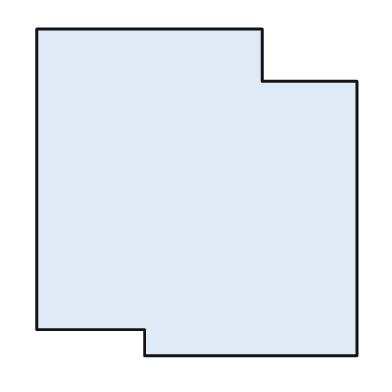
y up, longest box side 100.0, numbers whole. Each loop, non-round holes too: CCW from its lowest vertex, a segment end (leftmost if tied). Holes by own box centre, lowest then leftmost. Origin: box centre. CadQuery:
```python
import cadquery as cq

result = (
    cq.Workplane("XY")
    .moveTo(-16.0, -50.0)
    .lineTo(49.0, -50.0)
    .lineTo(49.0, 34.0)
    .lineTo(20.0, 34.0)
    .lineTo(20.0, 50.0)
    .lineTo(-49.0, 50.0)
    .lineTo(-49.0, -42.0)
    .lineTo(-16.0, -42.0)
    .close()
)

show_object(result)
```